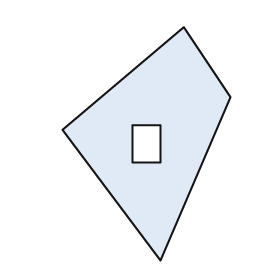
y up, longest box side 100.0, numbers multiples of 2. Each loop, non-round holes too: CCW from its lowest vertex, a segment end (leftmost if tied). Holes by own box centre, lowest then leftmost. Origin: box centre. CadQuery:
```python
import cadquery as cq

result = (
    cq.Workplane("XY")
    .moveTo(6.0, -50.0)
    .lineTo(36.0, 20.0)
    .lineTo(16.0, 50.0)
    .lineTo(-36.0, 6.0)
    .close()
    .moveTo(-6.0, -8.0)
    .lineTo(6.0, -8.0)
    .lineTo(6.0, 8.0)
    .lineTo(-6.0, 8.0)
    .close()
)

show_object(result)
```